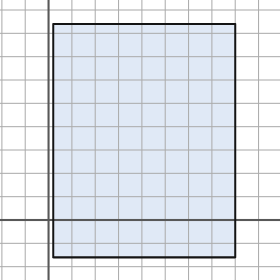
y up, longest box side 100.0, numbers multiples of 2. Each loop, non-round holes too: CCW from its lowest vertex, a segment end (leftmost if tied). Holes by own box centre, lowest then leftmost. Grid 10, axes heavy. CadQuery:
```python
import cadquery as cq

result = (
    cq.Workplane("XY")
    .moveTo(2.0, -16.0)
    .lineTo(80.0, -16.0)
    .lineTo(80.0, 84.0)
    .lineTo(2.0, 84.0)
    .close()
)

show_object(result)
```